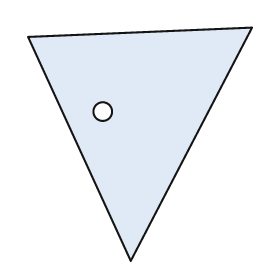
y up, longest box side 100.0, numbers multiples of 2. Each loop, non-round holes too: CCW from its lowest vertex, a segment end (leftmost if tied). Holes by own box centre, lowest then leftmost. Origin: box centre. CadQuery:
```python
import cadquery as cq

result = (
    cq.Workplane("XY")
    .moveTo(-4.0, -50.0)
    .lineTo(48.0, 50.0)
    .lineTo(-48.0, 46.0)
    .close()
    .moveTo(-16.0, 14.0)
    .circle(4.0)
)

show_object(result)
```